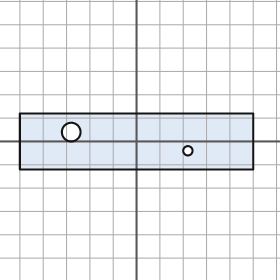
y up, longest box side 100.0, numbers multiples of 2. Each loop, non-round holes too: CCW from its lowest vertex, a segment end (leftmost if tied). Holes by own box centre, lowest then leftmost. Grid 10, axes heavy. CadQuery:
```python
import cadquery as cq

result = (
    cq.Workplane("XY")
    .moveTo(-50.0, -12.0)
    .lineTo(50.0, -12.0)
    .lineTo(50.0, 12.0)
    .lineTo(-50.0, 12.0)
    .close()
    .moveTo(22.0, -4.0)
    .circle(2.0)
    .moveTo(-28.0, 4.0)
    .circle(4.0)
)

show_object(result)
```